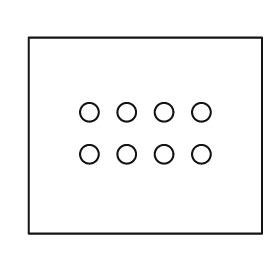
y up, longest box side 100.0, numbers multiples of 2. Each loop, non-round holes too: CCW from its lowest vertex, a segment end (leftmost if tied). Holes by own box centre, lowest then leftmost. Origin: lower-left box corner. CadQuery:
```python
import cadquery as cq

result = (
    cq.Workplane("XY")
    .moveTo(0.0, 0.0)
    .lineTo(100.0, 0.0)
    .lineTo(100.0, 84.0)
    .lineTo(0.0, 84.0)
    .close()
    .moveTo(26.0, 34.0)
    .circle(4.0)
    .moveTo(42.0, 34.0)
    .circle(4.0)
    .moveTo(58.0, 34.0)
    .circle(4.0)
    .moveTo(74.0, 34.0)
    .circle(4.0)
    .moveTo(26.0, 52.0)
    .circle(4.0)
    .moveTo(42.0, 52.0)
    .circle(4.0)
    .moveTo(58.0, 52.0)
    .circle(4.0)
    .moveTo(74.0, 52.0)
    .circle(4.0)
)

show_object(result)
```